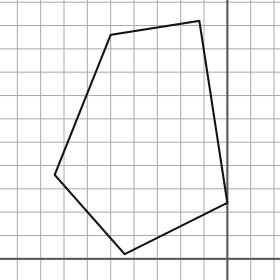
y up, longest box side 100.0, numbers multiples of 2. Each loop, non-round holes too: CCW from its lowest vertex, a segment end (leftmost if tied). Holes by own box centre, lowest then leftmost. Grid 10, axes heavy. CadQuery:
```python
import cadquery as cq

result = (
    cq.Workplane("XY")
    .moveTo(-44.0, 2.0)
    .lineTo(0.0, 24.0)
    .lineTo(-12.0, 102.0)
    .lineTo(-50.0, 96.0)
    .lineTo(-74.0, 36.0)
    .close()
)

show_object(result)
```